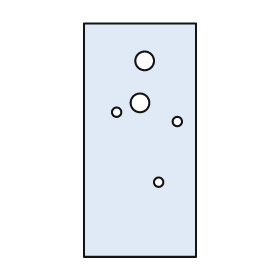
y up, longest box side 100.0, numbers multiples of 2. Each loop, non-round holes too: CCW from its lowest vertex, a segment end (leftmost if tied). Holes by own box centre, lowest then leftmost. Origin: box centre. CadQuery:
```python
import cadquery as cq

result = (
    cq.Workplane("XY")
    .moveTo(-24.0, -50.0)
    .lineTo(24.0, -50.0)
    .lineTo(24.0, 50.0)
    .lineTo(-24.0, 50.0)
    .close()
    .moveTo(8.0, -18.0)
    .circle(2.0)
    .moveTo(16.0, 8.0)
    .circle(2.0)
    .moveTo(-10.0, 12.0)
    .circle(2.0)
    .moveTo(0.0, 16.0)
    .circle(4.0)
    .moveTo(2.0, 34.0)
    .circle(4.0)
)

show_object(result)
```